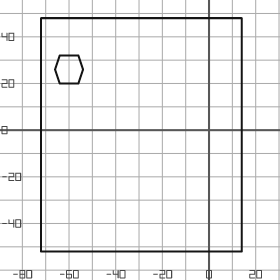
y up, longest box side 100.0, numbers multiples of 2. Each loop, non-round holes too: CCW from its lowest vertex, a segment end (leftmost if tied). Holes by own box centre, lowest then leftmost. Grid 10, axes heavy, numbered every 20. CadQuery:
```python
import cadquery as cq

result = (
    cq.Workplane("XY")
    .moveTo(-72.0, -52.0)
    .lineTo(14.0, -52.0)
    .lineTo(14.0, 48.0)
    .lineTo(-72.0, 48.0)
    .close()
    .moveTo(-64.0, 20.0)
    .lineTo(-56.0, 20.0)
    .lineTo(-54.0, 26.0)
    .lineTo(-56.0, 32.0)
    .lineTo(-64.0, 32.0)
    .lineTo(-66.0, 26.0)
    .close()
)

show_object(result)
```